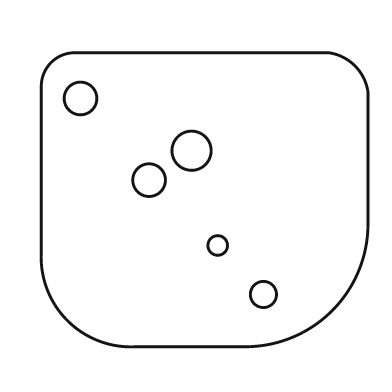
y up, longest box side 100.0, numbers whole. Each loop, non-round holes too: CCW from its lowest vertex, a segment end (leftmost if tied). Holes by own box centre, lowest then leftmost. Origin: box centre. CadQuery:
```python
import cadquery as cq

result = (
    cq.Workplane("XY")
    .moveTo(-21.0, -45.0)
    .lineTo(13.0, -45.0)
    .threePointArc((39.0, -34.0), (50.0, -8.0))
    .lineTo(50.0, 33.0)
    .threePointArc((46.0, 41.0), (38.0, 45.0))
    .lineTo(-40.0, 45.0)
    .threePointArc((-47.0, 42.0), (-50.0, 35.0))
    .lineTo(-50.0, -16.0)
    .threePointArc((-42.0, -37.0), (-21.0, -45.0))
    .close()
    .moveTo(18.0, -29.0)
    .circle(4.0)
    .moveTo(4.0, -14.0)
    .circle(3.0)
    .moveTo(-17.0, 6.0)
    .circle(5.0)
    .moveTo(-4.0, 15.0)
    .circle(6.0)
    .moveTo(-38.0, 31.0)
    .circle(5.0)
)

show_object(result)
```